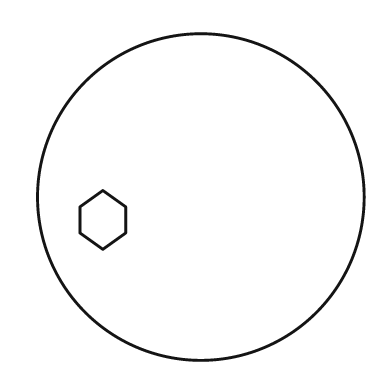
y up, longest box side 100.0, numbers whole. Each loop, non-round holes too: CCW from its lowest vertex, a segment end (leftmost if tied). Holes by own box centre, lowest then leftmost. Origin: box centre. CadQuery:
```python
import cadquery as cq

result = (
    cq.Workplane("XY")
    .moveTo(0.0, 0.0)
    .circle(50.0)
    .moveTo(-30.0, -16.0)
    .lineTo(-23.0, -11.0)
    .lineTo(-23.0, -3.0)
    .lineTo(-30.0, 2.0)
    .lineTo(-37.0, -3.0)
    .lineTo(-37.0, -11.0)
    .close()
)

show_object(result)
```